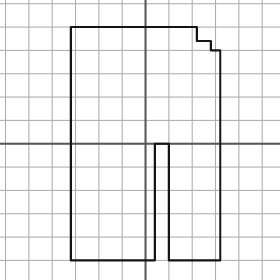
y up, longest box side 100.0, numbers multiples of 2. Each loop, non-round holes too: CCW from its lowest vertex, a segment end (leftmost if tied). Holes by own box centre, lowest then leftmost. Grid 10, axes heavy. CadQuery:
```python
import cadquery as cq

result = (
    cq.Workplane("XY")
    .moveTo(-32.0, -50.0)
    .lineTo(4.0, -50.0)
    .lineTo(4.0, 0.0)
    .lineTo(10.0, 0.0)
    .lineTo(10.0, -50.0)
    .lineTo(32.0, -50.0)
    .lineTo(32.0, 40.0)
    .lineTo(28.0, 40.0)
    .lineTo(28.0, 44.0)
    .lineTo(22.0, 44.0)
    .lineTo(22.0, 50.0)
    .lineTo(-32.0, 50.0)
    .close()
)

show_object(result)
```